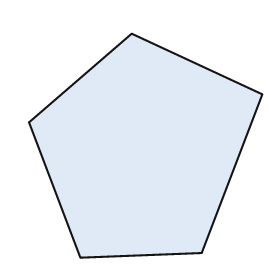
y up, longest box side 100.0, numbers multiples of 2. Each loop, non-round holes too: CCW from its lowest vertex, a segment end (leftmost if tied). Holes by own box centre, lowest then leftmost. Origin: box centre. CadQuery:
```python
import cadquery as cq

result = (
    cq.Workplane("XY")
    .moveTo(-28.0, -48.0)
    .lineTo(24.0, -46.0)
    .lineTo(50.0, 22.0)
    .lineTo(-6.0, 48.0)
    .lineTo(-50.0, 10.0)
    .close()
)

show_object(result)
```